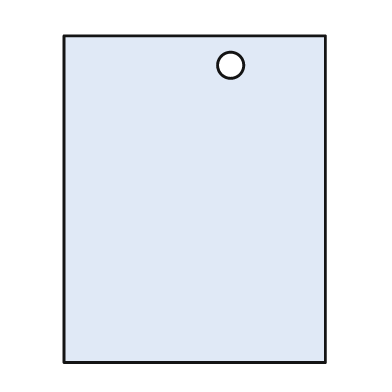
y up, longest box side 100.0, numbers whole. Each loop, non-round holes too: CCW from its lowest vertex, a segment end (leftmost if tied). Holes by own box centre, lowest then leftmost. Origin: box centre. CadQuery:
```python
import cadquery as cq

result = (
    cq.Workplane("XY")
    .moveTo(-40.0, -50.0)
    .lineTo(40.0, -50.0)
    .lineTo(40.0, 50.0)
    .lineTo(-40.0, 50.0)
    .close()
    .moveTo(11.0, 41.0)
    .circle(4.0)
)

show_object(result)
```